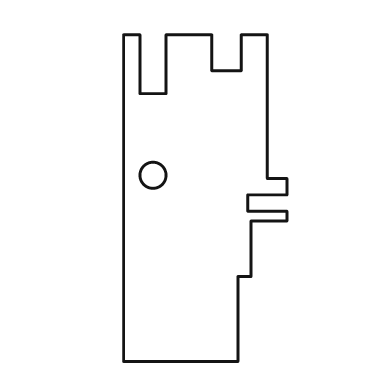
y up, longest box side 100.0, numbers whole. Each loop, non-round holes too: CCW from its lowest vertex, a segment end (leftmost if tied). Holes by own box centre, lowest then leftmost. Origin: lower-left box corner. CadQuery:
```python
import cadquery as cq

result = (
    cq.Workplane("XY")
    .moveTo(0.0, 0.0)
    .lineTo(35.0, 0.0)
    .lineTo(35.0, 26.0)
    .lineTo(39.0, 26.0)
    .lineTo(39.0, 43.0)
    .lineTo(50.0, 43.0)
    .lineTo(50.0, 46.0)
    .lineTo(38.0, 46.0)
    .lineTo(38.0, 51.0)
    .lineTo(50.0, 51.0)
    .lineTo(50.0, 56.0)
    .lineTo(44.0, 56.0)
    .lineTo(44.0, 100.0)
    .lineTo(36.0, 100.0)
    .lineTo(36.0, 89.0)
    .lineTo(27.0, 89.0)
    .lineTo(27.0, 100.0)
    .lineTo(13.0, 100.0)
    .lineTo(13.0, 82.0)
    .lineTo(5.0, 82.0)
    .lineTo(5.0, 100.0)
    .lineTo(0.0, 100.0)
    .close()
    .moveTo(9.0, 57.0)
    .circle(4.0)
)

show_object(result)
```